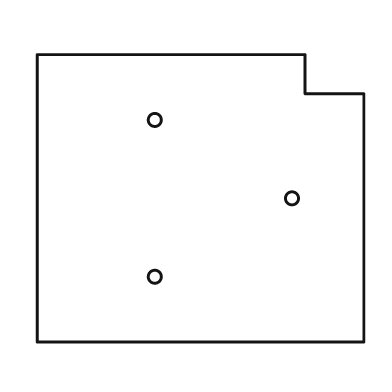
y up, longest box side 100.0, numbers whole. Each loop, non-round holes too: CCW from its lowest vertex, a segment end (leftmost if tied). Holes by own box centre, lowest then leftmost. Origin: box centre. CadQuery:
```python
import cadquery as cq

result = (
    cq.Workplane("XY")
    .moveTo(-50.0, -44.0)
    .lineTo(50.0, -44.0)
    .lineTo(50.0, 32.0)
    .lineTo(32.0, 32.0)
    .lineTo(32.0, 44.0)
    .lineTo(-50.0, 44.0)
    .close()
    .moveTo(-14.0, -24.0)
    .circle(2.0)
    .moveTo(28.0, 0.0)
    .circle(2.0)
    .moveTo(-14.0, 24.0)
    .circle(2.0)
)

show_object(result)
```